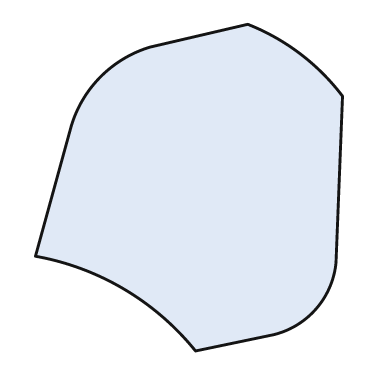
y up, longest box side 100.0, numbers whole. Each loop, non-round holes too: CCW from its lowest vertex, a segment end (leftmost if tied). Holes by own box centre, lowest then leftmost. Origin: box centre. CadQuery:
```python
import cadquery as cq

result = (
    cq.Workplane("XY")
    .moveTo(2.0, -50.0)
    .lineTo(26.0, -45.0)
    .threePointArc((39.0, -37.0), (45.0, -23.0))
    .lineTo(47.0, 28.0)
    .threePointArc((34.0, 41.0), (18.0, 50.0))
    .lineTo(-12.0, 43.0)
    .threePointArc((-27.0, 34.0), (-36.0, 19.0))
    .lineTo(-47.0, -21.0)
    .threePointArc((-20.0, -31.0), (2.0, -50.0))
    .close()
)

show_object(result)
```